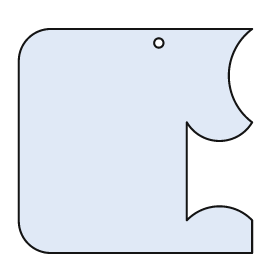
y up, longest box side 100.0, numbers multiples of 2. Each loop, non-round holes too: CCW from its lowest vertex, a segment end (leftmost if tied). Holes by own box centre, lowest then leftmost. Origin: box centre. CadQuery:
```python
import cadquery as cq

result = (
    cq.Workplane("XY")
    .moveTo(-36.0, -48.0)
    .lineTo(50.0, -48.0)
    .lineTo(50.0, -34.0)
    .threePointArc((36.0, -28.0), (22.0, -34.0))
    .lineTo(22.0, 8.0)
    .threePointArc((36.0, 0.0), (50.0, 8.0))
    .threePointArc((40.0, 28.0), (50.0, 48.0))
    .lineTo(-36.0, 48.0)
    .threePointArc((-46.0, 44.0), (-50.0, 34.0))
    .lineTo(-50.0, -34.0)
    .threePointArc((-46.0, -44.0), (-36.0, -48.0))
    .close()
    .moveTo(10.0, 42.0)
    .circle(2.0)
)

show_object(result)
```